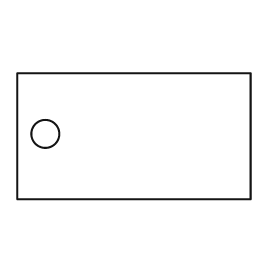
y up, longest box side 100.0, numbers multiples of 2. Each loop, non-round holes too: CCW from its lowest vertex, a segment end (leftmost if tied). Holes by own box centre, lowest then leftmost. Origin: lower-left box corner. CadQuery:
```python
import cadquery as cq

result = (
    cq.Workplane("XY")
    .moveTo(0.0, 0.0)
    .lineTo(100.0, 0.0)
    .lineTo(100.0, 54.0)
    .lineTo(0.0, 54.0)
    .close()
    .moveTo(12.0, 28.0)
    .circle(6.0)
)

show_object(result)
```